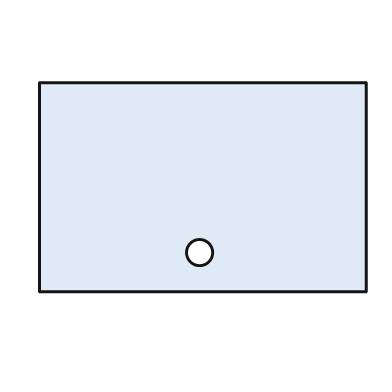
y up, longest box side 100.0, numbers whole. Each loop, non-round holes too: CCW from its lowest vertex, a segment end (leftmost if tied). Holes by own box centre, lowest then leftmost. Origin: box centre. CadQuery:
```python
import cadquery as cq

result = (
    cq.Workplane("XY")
    .moveTo(-50.0, -32.0)
    .lineTo(50.0, -32.0)
    .lineTo(50.0, 32.0)
    .lineTo(-50.0, 32.0)
    .close()
    .moveTo(-1.0, -20.0)
    .circle(4.0)
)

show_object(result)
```